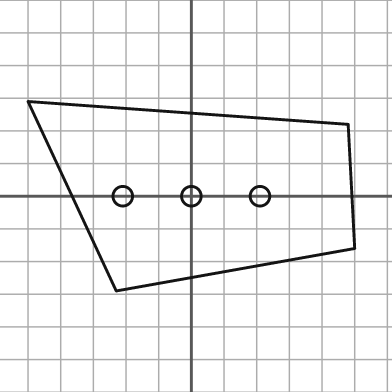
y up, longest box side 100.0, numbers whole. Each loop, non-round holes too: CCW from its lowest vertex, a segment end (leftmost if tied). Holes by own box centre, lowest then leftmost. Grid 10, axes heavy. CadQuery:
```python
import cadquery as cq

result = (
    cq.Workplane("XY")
    .moveTo(-23.0, -29.0)
    .lineTo(50.0, -16.0)
    .lineTo(48.0, 22.0)
    .lineTo(-50.0, 29.0)
    .close()
    .moveTo(-21.0, 0.0)
    .circle(3.0)
    .moveTo(0.0, 0.0)
    .circle(3.0)
    .moveTo(21.0, 0.0)
    .circle(3.0)
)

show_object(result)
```